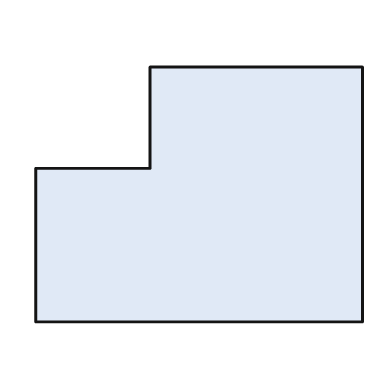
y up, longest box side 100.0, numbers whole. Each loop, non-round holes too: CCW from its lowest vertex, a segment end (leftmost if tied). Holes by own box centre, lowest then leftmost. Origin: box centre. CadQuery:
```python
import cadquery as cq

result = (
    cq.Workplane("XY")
    .moveTo(-50.0, -39.0)
    .lineTo(50.0, -39.0)
    .lineTo(50.0, 39.0)
    .lineTo(-15.0, 39.0)
    .lineTo(-15.0, 8.0)
    .lineTo(-50.0, 8.0)
    .close()
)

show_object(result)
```